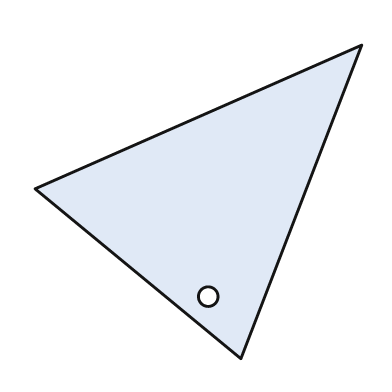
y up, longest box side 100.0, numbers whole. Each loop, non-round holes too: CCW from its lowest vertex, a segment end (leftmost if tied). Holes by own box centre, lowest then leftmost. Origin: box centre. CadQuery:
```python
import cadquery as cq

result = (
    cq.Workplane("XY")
    .moveTo(13.0, -48.0)
    .lineTo(50.0, 48.0)
    .lineTo(-50.0, 4.0)
    .close()
    .moveTo(3.0, -29.0)
    .circle(3.0)
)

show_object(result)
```